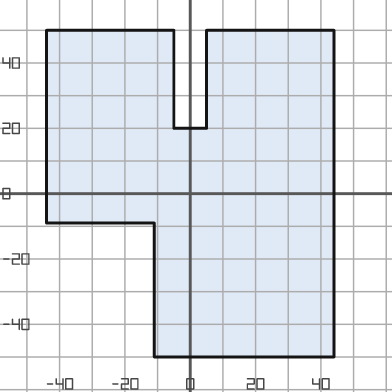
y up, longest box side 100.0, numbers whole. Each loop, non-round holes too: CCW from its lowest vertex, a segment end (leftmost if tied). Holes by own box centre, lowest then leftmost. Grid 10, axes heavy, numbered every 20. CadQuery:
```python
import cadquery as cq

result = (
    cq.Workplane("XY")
    .moveTo(-11.0, -50.0)
    .lineTo(44.0, -50.0)
    .lineTo(44.0, 50.0)
    .lineTo(5.0, 50.0)
    .lineTo(5.0, 20.0)
    .lineTo(-5.0, 20.0)
    .lineTo(-5.0, 50.0)
    .lineTo(-44.0, 50.0)
    .lineTo(-44.0, -9.0)
    .lineTo(-11.0, -9.0)
    .close()
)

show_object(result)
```